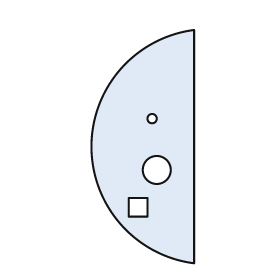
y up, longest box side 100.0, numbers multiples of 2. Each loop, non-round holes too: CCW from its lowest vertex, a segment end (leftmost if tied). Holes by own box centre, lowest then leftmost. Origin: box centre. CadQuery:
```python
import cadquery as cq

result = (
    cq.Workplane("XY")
    .moveTo(22.0, -50.0)
    .lineTo(22.0, 50.0)
    .threePointArc((-22.0, 0.0), (22.0, -50.0))
    .close()
    .moveTo(-6.0, -30.0)
    .lineTo(2.0, -30.0)
    .lineTo(2.0, -22.0)
    .lineTo(-6.0, -22.0)
    .close()
    .moveTo(6.0, -10.0)
    .circle(6.0)
    .moveTo(4.0, 12.0)
    .circle(2.0)
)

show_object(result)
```